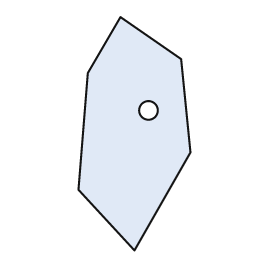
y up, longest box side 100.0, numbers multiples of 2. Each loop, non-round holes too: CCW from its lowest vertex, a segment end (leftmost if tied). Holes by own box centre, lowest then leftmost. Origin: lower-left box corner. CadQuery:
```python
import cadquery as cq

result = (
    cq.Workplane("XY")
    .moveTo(24.0, 0.0)
    .lineTo(48.0, 42.0)
    .lineTo(44.0, 82.0)
    .lineTo(18.0, 100.0)
    .lineTo(4.0, 76.0)
    .lineTo(0.0, 26.0)
    .close()
    .moveTo(30.0, 60.0)
    .circle(4.0)
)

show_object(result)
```